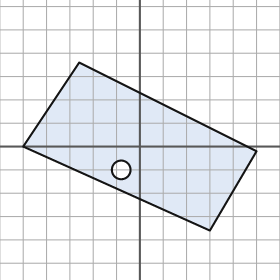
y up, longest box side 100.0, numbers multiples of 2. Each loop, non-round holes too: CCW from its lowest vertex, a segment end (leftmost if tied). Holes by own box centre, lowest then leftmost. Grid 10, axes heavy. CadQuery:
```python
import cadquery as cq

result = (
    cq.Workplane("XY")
    .moveTo(30.0, -36.0)
    .lineTo(50.0, -2.0)
    .lineTo(-26.0, 36.0)
    .lineTo(-50.0, 0.0)
    .close()
    .moveTo(-8.0, -10.0)
    .circle(4.0)
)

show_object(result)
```